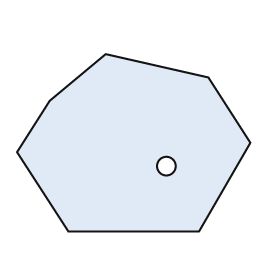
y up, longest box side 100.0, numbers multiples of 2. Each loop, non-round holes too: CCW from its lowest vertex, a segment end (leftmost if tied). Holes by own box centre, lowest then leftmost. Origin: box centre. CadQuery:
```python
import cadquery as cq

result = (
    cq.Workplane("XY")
    .moveTo(-28.0, -38.0)
    .lineTo(28.0, -38.0)
    .lineTo(50.0, 0.0)
    .lineTo(32.0, 28.0)
    .lineTo(-12.0, 38.0)
    .lineTo(-36.0, 18.0)
    .lineTo(-50.0, -4.0)
    .close()
    .moveTo(14.0, -10.0)
    .circle(4.0)
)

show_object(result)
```